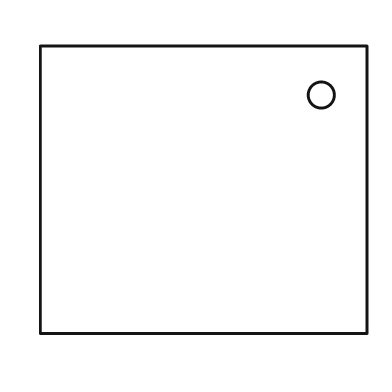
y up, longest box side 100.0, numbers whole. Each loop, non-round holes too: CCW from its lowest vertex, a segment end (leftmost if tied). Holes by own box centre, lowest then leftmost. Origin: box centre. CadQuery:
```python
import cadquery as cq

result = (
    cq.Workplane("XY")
    .moveTo(-50.0, -44.0)
    .lineTo(50.0, -44.0)
    .lineTo(50.0, 44.0)
    .lineTo(-50.0, 44.0)
    .close()
    .moveTo(36.0, 29.0)
    .circle(4.0)
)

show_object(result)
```